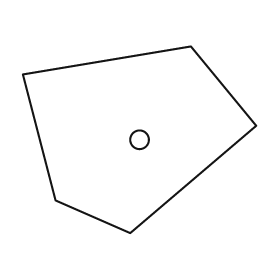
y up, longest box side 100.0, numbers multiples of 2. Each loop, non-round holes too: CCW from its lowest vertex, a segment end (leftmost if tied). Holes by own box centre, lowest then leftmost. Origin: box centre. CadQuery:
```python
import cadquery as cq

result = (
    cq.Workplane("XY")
    .moveTo(-4.0, -40.0)
    .lineTo(50.0, 6.0)
    .lineTo(22.0, 40.0)
    .lineTo(-50.0, 28.0)
    .lineTo(-36.0, -26.0)
    .close()
    .moveTo(0.0, 0.0)
    .circle(4.0)
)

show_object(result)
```